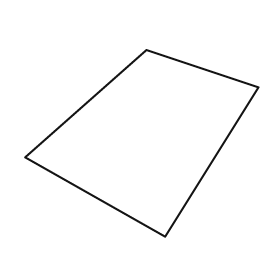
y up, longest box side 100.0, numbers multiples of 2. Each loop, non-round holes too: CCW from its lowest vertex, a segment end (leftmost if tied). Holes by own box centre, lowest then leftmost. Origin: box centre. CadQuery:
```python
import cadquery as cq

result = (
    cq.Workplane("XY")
    .moveTo(10.0, -40.0)
    .lineTo(50.0, 24.0)
    .lineTo(2.0, 40.0)
    .lineTo(-50.0, -6.0)
    .close()
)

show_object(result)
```